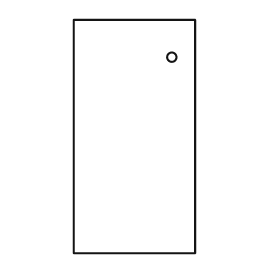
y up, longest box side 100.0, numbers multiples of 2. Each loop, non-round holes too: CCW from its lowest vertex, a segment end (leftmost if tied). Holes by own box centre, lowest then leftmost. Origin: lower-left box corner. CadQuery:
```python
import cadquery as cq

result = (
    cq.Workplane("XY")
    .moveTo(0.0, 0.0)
    .lineTo(52.0, 0.0)
    .lineTo(52.0, 100.0)
    .lineTo(0.0, 100.0)
    .close()
    .moveTo(42.0, 84.0)
    .circle(2.0)
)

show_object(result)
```